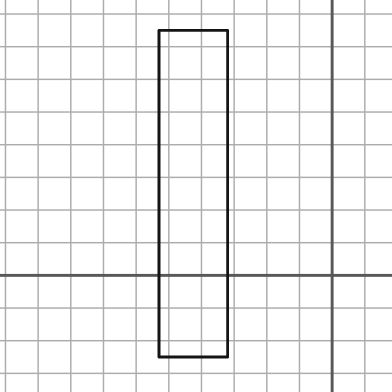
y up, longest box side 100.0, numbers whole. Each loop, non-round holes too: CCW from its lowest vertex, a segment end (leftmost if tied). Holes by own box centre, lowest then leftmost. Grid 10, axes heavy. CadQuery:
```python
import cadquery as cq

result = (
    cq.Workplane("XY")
    .moveTo(-53.0, -25.0)
    .lineTo(-32.0, -25.0)
    .lineTo(-32.0, 75.0)
    .lineTo(-53.0, 75.0)
    .close()
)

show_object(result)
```